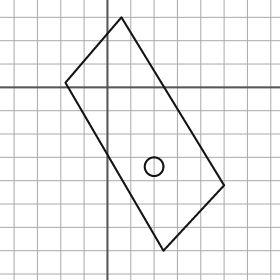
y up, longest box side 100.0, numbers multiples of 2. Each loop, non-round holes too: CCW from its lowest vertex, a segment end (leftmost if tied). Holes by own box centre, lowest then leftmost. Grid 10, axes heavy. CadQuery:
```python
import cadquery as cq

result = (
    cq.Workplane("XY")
    .moveTo(24.0, -70.0)
    .lineTo(50.0, -42.0)
    .lineTo(6.0, 30.0)
    .lineTo(-18.0, 2.0)
    .close()
    .moveTo(20.0, -34.0)
    .circle(4.0)
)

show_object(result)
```